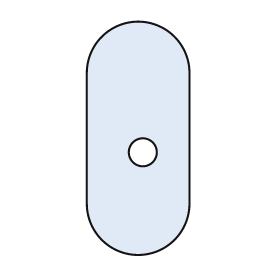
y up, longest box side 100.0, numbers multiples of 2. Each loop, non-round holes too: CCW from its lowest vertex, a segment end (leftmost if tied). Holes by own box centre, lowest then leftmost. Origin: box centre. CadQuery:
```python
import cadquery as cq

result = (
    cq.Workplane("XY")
    .moveTo(-22.0, -28.0)
    .threePointArc((0.0, -50.0), (22.0, -28.0))
    .lineTo(22.0, 28.0)
    .threePointArc((0.0, 50.0), (-22.0, 28.0))
    .close()
    .moveTo(2.0, -6.0)
    .circle(6.0)
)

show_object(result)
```